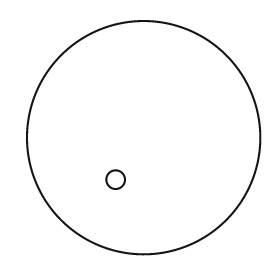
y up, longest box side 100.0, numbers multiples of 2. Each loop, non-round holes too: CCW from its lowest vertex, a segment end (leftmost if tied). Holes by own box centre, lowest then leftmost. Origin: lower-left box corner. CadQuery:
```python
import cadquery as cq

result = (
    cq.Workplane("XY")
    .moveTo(50.0, 50.0)
    .circle(50.0)
    .moveTo(38.0, 32.0)
    .circle(4.0)
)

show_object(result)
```